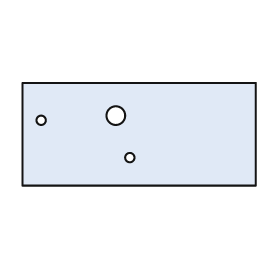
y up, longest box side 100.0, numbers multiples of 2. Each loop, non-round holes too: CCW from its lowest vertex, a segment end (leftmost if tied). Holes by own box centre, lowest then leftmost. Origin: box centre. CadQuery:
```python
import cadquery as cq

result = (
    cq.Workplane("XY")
    .moveTo(-50.0, -22.0)
    .lineTo(50.0, -22.0)
    .lineTo(50.0, 22.0)
    .lineTo(-50.0, 22.0)
    .close()
    .moveTo(-4.0, -10.0)
    .circle(2.0)
    .moveTo(-42.0, 6.0)
    .circle(2.0)
    .moveTo(-10.0, 8.0)
    .circle(4.0)
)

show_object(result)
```